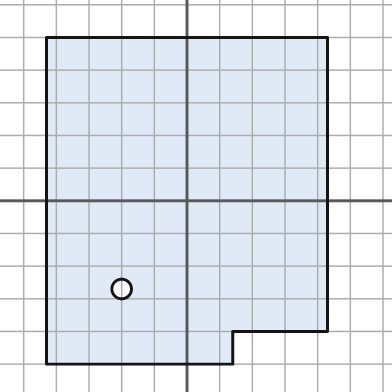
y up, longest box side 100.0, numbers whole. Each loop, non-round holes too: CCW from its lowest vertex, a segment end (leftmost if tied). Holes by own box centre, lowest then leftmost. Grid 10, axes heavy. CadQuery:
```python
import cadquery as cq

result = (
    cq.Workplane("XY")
    .moveTo(-43.0, -50.0)
    .lineTo(14.0, -50.0)
    .lineTo(14.0, -40.0)
    .lineTo(43.0, -40.0)
    .lineTo(43.0, 50.0)
    .lineTo(-43.0, 50.0)
    .close()
    .moveTo(-20.0, -27.0)
    .circle(3.0)
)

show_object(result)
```